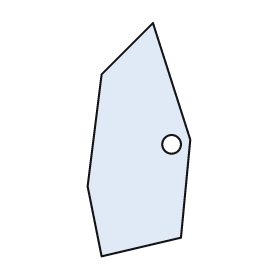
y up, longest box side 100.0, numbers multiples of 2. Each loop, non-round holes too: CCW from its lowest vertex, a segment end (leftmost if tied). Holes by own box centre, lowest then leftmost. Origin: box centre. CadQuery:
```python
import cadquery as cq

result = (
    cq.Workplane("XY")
    .moveTo(-16.0, -50.0)
    .lineTo(18.0, -42.0)
    .lineTo(22.0, 0.0)
    .lineTo(6.0, 50.0)
    .lineTo(-16.0, 28.0)
    .lineTo(-22.0, -20.0)
    .close()
    .moveTo(14.0, -2.0)
    .circle(4.0)
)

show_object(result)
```